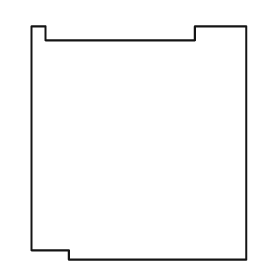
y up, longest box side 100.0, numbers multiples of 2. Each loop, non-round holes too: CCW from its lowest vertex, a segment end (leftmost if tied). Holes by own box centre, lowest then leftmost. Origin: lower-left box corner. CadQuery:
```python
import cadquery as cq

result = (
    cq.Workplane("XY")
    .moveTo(16.0, 0.0)
    .lineTo(92.0, 0.0)
    .lineTo(92.0, 100.0)
    .lineTo(70.0, 100.0)
    .lineTo(70.0, 94.0)
    .lineTo(6.0, 94.0)
    .lineTo(6.0, 100.0)
    .lineTo(0.0, 100.0)
    .lineTo(0.0, 4.0)
    .lineTo(16.0, 4.0)
    .close()
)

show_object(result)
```